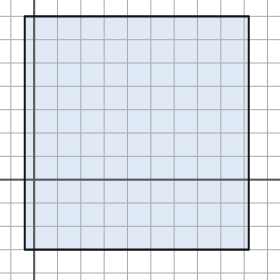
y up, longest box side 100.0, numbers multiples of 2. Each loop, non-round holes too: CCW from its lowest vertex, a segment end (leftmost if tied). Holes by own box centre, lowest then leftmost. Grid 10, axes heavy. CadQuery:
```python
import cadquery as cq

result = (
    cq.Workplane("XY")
    .moveTo(-4.0, -30.0)
    .lineTo(92.0, -30.0)
    .lineTo(92.0, 70.0)
    .lineTo(-4.0, 70.0)
    .close()
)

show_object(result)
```